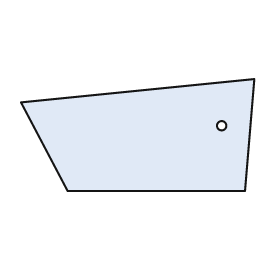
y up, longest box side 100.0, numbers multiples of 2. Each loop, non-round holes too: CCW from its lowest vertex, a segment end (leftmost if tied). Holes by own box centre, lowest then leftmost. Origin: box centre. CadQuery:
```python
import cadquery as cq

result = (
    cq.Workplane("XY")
    .moveTo(-30.0, -24.0)
    .lineTo(46.0, -24.0)
    .lineTo(50.0, 24.0)
    .lineTo(-50.0, 14.0)
    .close()
    .moveTo(36.0, 4.0)
    .circle(2.0)
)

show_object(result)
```